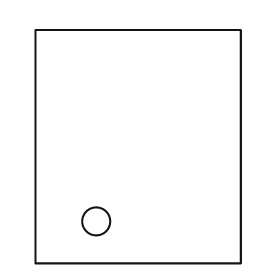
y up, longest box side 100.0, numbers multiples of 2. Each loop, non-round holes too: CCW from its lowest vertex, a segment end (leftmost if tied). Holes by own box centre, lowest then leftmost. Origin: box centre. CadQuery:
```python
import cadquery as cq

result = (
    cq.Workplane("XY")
    .moveTo(-44.0, -50.0)
    .lineTo(44.0, -50.0)
    .lineTo(44.0, 50.0)
    .lineTo(-44.0, 50.0)
    .close()
    .moveTo(-18.0, -32.0)
    .circle(6.0)
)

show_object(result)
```